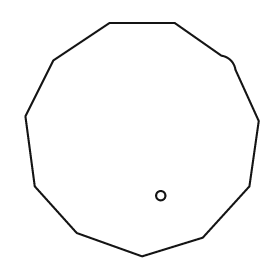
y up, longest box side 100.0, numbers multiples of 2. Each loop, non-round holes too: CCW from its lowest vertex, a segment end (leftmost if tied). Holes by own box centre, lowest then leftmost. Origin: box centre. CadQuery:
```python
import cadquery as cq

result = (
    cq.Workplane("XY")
    .moveTo(0.0, -50.0)
    .lineTo(26.0, -42.0)
    .lineTo(46.0, -20.0)
    .lineTo(50.0, 8.0)
    .lineTo(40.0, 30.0)
    .threePointArc((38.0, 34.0), (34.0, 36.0))
    .lineTo(14.0, 50.0)
    .lineTo(-14.0, 50.0)
    .lineTo(-38.0, 34.0)
    .lineTo(-50.0, 10.0)
    .lineTo(-46.0, -20.0)
    .lineTo(-28.0, -40.0)
    .close()
    .moveTo(8.0, -24.0)
    .circle(2.0)
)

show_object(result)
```